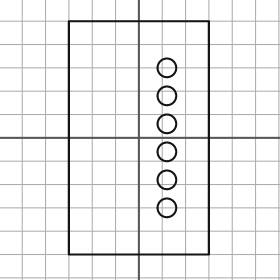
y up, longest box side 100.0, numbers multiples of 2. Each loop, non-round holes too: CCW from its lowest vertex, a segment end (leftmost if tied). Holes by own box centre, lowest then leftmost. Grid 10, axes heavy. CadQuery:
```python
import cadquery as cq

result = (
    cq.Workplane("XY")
    .moveTo(-30.0, -50.0)
    .lineTo(30.0, -50.0)
    .lineTo(30.0, 50.0)
    .lineTo(-30.0, 50.0)
    .close()
    .moveTo(12.0, -30.0)
    .circle(4.0)
    .moveTo(12.0, -18.0)
    .circle(4.0)
    .moveTo(12.0, -6.0)
    .circle(4.0)
    .moveTo(12.0, 6.0)
    .circle(4.0)
    .moveTo(12.0, 18.0)
    .circle(4.0)
    .moveTo(12.0, 30.0)
    .circle(4.0)
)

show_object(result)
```